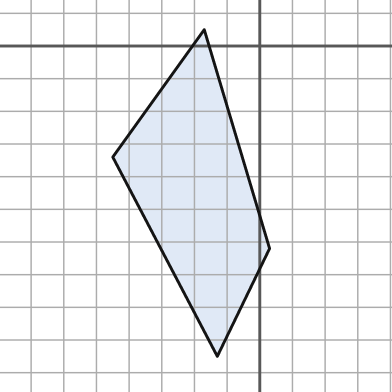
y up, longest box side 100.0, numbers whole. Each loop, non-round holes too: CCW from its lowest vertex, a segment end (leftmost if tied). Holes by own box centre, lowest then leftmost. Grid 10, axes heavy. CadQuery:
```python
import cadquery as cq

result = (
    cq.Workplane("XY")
    .moveTo(-13.0, -95.0)
    .lineTo(3.0, -62.0)
    .lineTo(-17.0, 5.0)
    .lineTo(-45.0, -34.0)
    .close()
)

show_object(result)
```